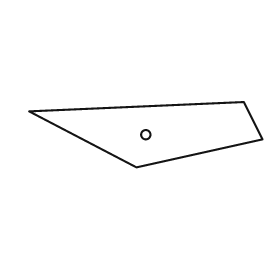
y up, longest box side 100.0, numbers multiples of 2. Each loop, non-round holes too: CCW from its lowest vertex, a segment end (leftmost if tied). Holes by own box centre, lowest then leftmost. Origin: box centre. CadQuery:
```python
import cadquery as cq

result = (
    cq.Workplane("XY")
    .moveTo(-4.0, -14.0)
    .lineTo(50.0, -2.0)
    .lineTo(42.0, 14.0)
    .lineTo(-50.0, 10.0)
    .close()
    .moveTo(0.0, 0.0)
    .circle(2.0)
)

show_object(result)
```